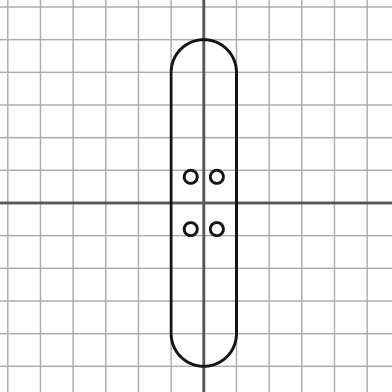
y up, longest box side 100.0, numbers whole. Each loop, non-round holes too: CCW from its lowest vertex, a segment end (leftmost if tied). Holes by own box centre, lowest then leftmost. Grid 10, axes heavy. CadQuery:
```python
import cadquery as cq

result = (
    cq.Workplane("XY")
    .moveTo(-10.0, -40.0)
    .threePointArc((0.0, -50.0), (10.0, -40.0))
    .lineTo(10.0, 40.0)
    .threePointArc((0.0, 50.0), (-10.0, 40.0))
    .close()
    .moveTo(-4.0, -8.0)
    .circle(2.0)
    .moveTo(4.0, -8.0)
    .circle(2.0)
    .moveTo(-4.0, 8.0)
    .circle(2.0)
    .moveTo(4.0, 8.0)
    .circle(2.0)
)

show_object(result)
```